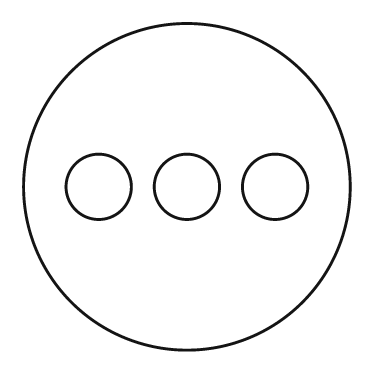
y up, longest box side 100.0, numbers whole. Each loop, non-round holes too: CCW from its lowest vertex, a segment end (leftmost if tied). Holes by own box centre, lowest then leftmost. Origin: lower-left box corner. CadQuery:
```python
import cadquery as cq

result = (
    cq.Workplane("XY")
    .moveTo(50.0, 50.0)
    .circle(50.0)
    .moveTo(23.0, 50.0)
    .circle(10.0)
    .moveTo(50.0, 50.0)
    .circle(10.0)
    .moveTo(77.0, 50.0)
    .circle(10.0)
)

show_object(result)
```